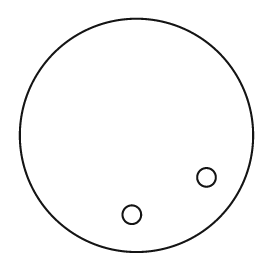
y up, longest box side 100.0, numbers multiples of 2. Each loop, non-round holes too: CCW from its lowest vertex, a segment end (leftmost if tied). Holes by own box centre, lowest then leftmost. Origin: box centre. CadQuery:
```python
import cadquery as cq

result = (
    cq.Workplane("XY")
    .moveTo(0.0, 0.0)
    .circle(50.0)
    .moveTo(-2.0, -34.0)
    .circle(4.0)
    .moveTo(30.0, -18.0)
    .circle(4.0)
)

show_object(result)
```